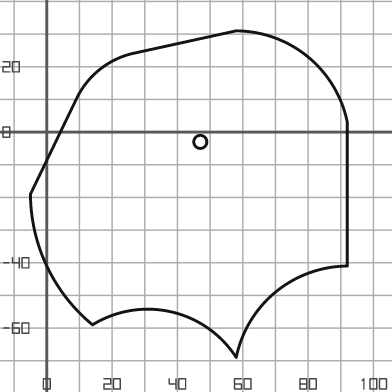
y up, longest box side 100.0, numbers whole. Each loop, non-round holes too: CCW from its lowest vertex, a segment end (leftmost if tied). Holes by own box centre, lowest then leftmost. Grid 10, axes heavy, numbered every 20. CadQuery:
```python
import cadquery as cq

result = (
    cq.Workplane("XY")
    .moveTo(58.0, -69.0)
    .threePointArc((70.0, -49.0), (92.0, -41.0))
    .lineTo(92.0, 3.0)
    .threePointArc((80.0, 23.0), (58.0, 31.0))
    .lineTo(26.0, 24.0)
    .threePointArc((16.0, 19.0), (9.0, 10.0))
    .lineTo(-5.0, -19.0)
    .threePointArc((0.0, -41.0), (14.0, -59.0))
    .threePointArc((38.0, -55.0), (58.0, -69.0))
    .close()
    .moveTo(47.0, -3.0)
    .circle(2.0)
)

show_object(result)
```